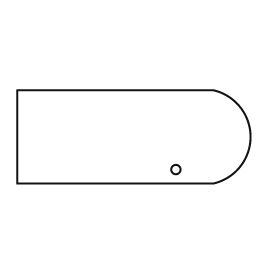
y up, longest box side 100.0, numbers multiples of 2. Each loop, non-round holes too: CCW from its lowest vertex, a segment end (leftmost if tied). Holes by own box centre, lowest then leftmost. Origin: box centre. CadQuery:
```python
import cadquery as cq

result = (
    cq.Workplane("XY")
    .moveTo(-50.0, -20.0)
    .lineTo(34.0, -20.0)
    .threePointArc((50.0, 0.0), (34.0, 20.0))
    .lineTo(-50.0, 20.0)
    .close()
    .moveTo(18.0, -14.0)
    .circle(2.0)
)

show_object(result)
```